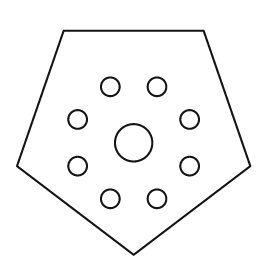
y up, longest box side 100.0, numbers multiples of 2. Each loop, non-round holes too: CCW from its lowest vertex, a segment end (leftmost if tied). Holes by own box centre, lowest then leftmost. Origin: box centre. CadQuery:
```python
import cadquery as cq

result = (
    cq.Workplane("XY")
    .moveTo(0.0, -48.0)
    .lineTo(50.0, -10.0)
    .lineTo(30.0, 48.0)
    .lineTo(-30.0, 48.0)
    .lineTo(-50.0, -10.0)
    .close()
    .moveTo(-10.0, -24.0)
    .circle(4.0)
    .moveTo(10.0, -24.0)
    .circle(4.0)
    .moveTo(-24.0, -10.0)
    .circle(4.0)
    .moveTo(24.0, -10.0)
    .circle(4.0)
    .moveTo(0.0, 0.0)
    .circle(8.0)
    .moveTo(-24.0, 10.0)
    .circle(4.0)
    .moveTo(24.0, 10.0)
    .circle(4.0)
    .moveTo(-10.0, 24.0)
    .circle(4.0)
    .moveTo(10.0, 24.0)
    .circle(4.0)
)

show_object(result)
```